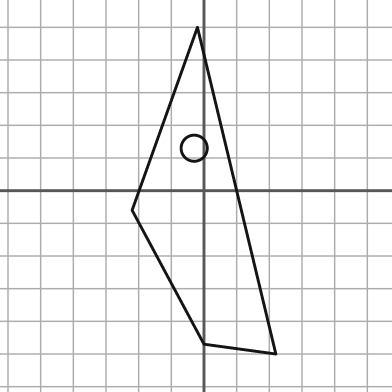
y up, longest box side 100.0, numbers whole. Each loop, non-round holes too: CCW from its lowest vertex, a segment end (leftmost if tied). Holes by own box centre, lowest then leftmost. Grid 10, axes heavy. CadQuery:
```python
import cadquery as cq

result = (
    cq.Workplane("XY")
    .moveTo(22.0, -50.0)
    .lineTo(-2.0, 50.0)
    .lineTo(-22.0, -6.0)
    .lineTo(0.0, -47.0)
    .close()
    .moveTo(-3.0, 13.0)
    .circle(4.0)
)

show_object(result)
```